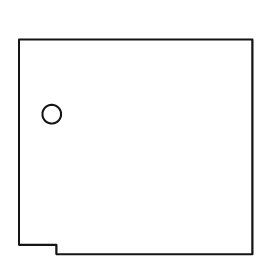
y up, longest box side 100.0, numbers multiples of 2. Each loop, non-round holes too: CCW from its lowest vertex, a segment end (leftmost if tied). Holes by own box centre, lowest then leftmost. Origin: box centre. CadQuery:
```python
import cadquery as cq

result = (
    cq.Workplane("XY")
    .moveTo(-34.0, -46.0)
    .lineTo(50.0, -46.0)
    .lineTo(50.0, 46.0)
    .lineTo(-50.0, 46.0)
    .lineTo(-50.0, -42.0)
    .lineTo(-34.0, -42.0)
    .close()
    .moveTo(-36.0, 14.0)
    .circle(4.0)
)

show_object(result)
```